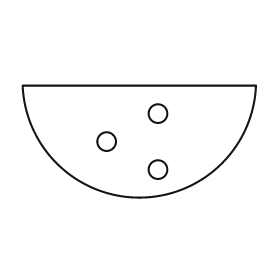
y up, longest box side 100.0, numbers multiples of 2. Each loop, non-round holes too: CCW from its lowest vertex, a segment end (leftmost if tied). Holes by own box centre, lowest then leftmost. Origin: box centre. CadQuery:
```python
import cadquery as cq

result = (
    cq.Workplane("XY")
    .moveTo(-50.0, 24.0)
    .threePointArc((0.0, -24.0), (50.0, 24.0))
    .close()
    .moveTo(8.0, -12.0)
    .circle(4.0)
    .moveTo(-14.0, 0.0)
    .circle(4.0)
    .moveTo(8.0, 12.0)
    .circle(4.0)
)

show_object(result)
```